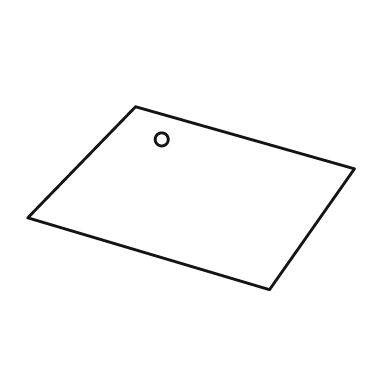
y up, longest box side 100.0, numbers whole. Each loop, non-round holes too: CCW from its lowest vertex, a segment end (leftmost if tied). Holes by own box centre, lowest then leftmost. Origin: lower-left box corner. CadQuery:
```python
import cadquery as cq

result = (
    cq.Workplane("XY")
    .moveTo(74.0, 0.0)
    .lineTo(100.0, 37.0)
    .lineTo(33.0, 56.0)
    .lineTo(0.0, 22.0)
    .close()
    .moveTo(41.0, 46.0)
    .circle(2.0)
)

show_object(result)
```